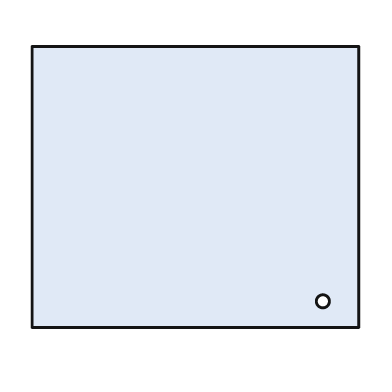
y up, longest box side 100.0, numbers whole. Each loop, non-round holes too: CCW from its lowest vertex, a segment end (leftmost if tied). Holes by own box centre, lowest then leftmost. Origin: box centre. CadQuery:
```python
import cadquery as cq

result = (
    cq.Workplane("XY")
    .moveTo(-50.0, -43.0)
    .lineTo(50.0, -43.0)
    .lineTo(50.0, 43.0)
    .lineTo(-50.0, 43.0)
    .close()
    .moveTo(39.0, -35.0)
    .circle(2.0)
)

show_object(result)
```